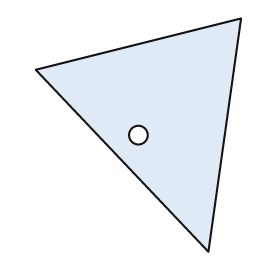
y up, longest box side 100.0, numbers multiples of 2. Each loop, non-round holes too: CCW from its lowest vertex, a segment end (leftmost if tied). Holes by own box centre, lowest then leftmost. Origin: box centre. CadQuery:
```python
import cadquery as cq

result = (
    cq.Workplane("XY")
    .moveTo(30.0, -50.0)
    .lineTo(44.0, 50.0)
    .lineTo(-44.0, 28.0)
    .close()
    .moveTo(0.0, 0.0)
    .circle(4.0)
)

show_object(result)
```